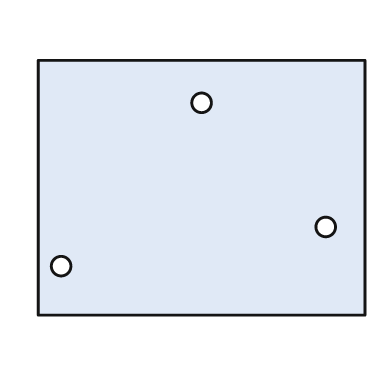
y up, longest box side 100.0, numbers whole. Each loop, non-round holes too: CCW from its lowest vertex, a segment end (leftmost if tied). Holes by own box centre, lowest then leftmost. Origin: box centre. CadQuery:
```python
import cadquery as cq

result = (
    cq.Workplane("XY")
    .moveTo(-50.0, -39.0)
    .lineTo(50.0, -39.0)
    .lineTo(50.0, 39.0)
    .lineTo(-50.0, 39.0)
    .close()
    .moveTo(-43.0, -24.0)
    .circle(3.0)
    .moveTo(38.0, -12.0)
    .circle(3.0)
    .moveTo(0.0, 26.0)
    .circle(3.0)
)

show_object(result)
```